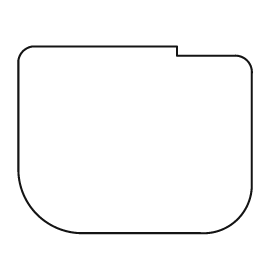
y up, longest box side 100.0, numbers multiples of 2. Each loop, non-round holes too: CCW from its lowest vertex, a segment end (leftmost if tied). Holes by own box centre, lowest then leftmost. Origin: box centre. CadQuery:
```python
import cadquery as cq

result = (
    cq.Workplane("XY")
    .moveTo(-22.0, -40.0)
    .lineTo(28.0, -40.0)
    .threePointArc((44.0, -34.0), (50.0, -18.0))
    .lineTo(50.0, 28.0)
    .threePointArc((48.0, 34.0), (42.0, 36.0))
    .lineTo(18.0, 36.0)
    .lineTo(18.0, 40.0)
    .lineTo(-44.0, 40.0)
    .threePointArc((-48.0, 38.0), (-50.0, 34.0))
    .lineTo(-50.0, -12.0)
    .threePointArc((-42.0, -32.0), (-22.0, -40.0))
    .close()
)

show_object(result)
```